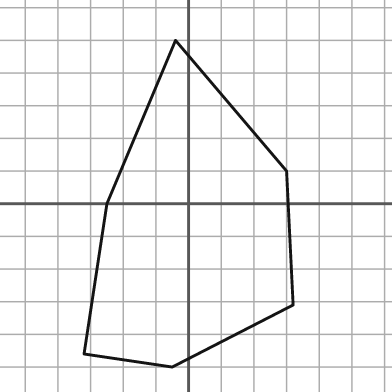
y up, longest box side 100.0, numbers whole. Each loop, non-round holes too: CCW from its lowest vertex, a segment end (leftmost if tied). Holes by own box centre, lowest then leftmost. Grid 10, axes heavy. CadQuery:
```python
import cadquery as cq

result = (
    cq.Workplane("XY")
    .moveTo(-5.0, -50.0)
    .lineTo(32.0, -31.0)
    .lineTo(30.0, 10.0)
    .lineTo(-4.0, 50.0)
    .lineTo(-25.0, 0.0)
    .lineTo(-32.0, -46.0)
    .close()
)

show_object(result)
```